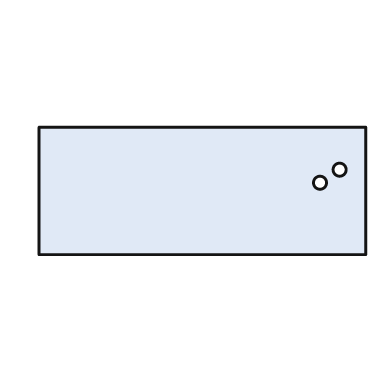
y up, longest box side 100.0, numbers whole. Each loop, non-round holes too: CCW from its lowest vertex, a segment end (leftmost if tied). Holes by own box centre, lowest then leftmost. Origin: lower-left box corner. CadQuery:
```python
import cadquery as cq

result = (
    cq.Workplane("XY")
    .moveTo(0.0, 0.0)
    .lineTo(100.0, 0.0)
    .lineTo(100.0, 39.0)
    .lineTo(0.0, 39.0)
    .close()
    .moveTo(86.0, 22.0)
    .circle(2.0)
    .moveTo(92.0, 26.0)
    .circle(2.0)
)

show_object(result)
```